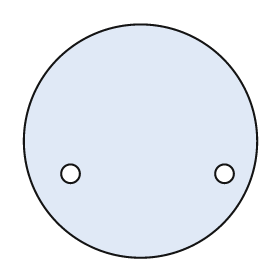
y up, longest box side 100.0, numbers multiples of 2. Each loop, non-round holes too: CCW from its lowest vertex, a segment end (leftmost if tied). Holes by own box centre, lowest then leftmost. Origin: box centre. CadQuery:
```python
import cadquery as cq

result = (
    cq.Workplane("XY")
    .moveTo(0.0, 0.0)
    .circle(50.0)
    .moveTo(-30.0, -14.0)
    .circle(4.0)
    .moveTo(36.0, -14.0)
    .circle(4.0)
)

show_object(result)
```